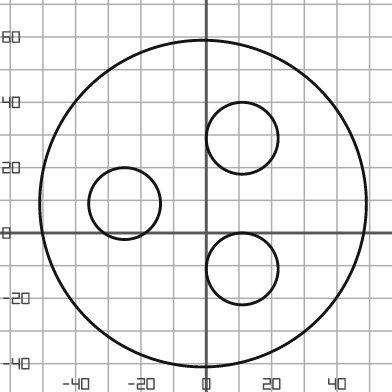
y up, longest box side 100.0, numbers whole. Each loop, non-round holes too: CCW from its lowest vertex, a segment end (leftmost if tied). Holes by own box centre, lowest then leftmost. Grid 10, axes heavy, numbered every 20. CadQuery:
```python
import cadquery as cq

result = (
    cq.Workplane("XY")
    .moveTo(-1.0, 9.0)
    .circle(50.0)
    .moveTo(11.0, -11.0)
    .circle(11.0)
    .moveTo(-25.0, 9.0)
    .circle(11.0)
    .moveTo(11.0, 29.0)
    .circle(11.0)
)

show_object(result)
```